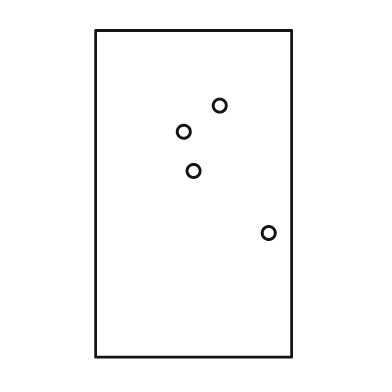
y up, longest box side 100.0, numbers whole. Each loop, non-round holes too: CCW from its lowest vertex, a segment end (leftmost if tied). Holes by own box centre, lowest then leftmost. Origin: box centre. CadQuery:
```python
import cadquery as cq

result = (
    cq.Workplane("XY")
    .moveTo(-30.0, -50.0)
    .lineTo(30.0, -50.0)
    .lineTo(30.0, 50.0)
    .lineTo(-30.0, 50.0)
    .close()
    .moveTo(23.0, -12.0)
    .circle(2.0)
    .moveTo(0.0, 7.0)
    .circle(2.0)
    .moveTo(-3.0, 19.0)
    .circle(2.0)
    .moveTo(8.0, 27.0)
    .circle(2.0)
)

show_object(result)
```